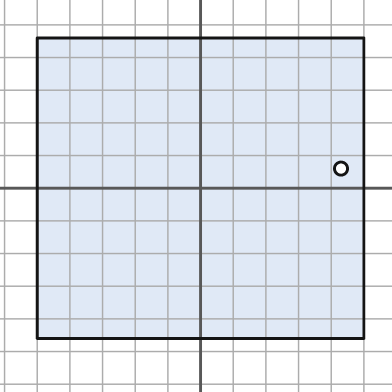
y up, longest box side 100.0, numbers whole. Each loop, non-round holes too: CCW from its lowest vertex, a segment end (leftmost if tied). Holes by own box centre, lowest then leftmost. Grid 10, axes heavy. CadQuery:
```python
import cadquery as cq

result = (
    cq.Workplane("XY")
    .moveTo(-50.0, -46.0)
    .lineTo(50.0, -46.0)
    .lineTo(50.0, 46.0)
    .lineTo(-50.0, 46.0)
    .close()
    .moveTo(43.0, 6.0)
    .circle(2.0)
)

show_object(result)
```